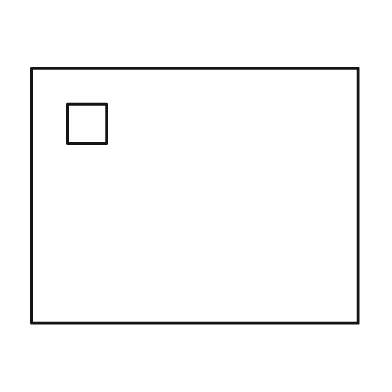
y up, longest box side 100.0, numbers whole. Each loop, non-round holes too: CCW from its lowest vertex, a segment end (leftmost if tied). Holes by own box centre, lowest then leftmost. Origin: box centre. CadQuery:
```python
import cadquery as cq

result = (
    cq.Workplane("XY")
    .moveTo(-50.0, -39.0)
    .lineTo(50.0, -39.0)
    .lineTo(50.0, 39.0)
    .lineTo(-50.0, 39.0)
    .close()
    .moveTo(-39.0, 16.0)
    .lineTo(-27.0, 16.0)
    .lineTo(-27.0, 28.0)
    .lineTo(-39.0, 28.0)
    .close()
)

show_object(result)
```